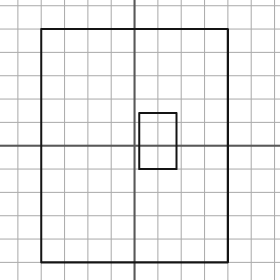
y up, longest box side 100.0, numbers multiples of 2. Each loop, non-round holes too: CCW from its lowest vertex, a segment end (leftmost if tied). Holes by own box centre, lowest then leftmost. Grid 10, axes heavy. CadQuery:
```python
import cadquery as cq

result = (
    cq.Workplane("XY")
    .moveTo(-40.0, -50.0)
    .lineTo(40.0, -50.0)
    .lineTo(40.0, 50.0)
    .lineTo(-40.0, 50.0)
    .close()
    .moveTo(2.0, -10.0)
    .lineTo(18.0, -10.0)
    .lineTo(18.0, 14.0)
    .lineTo(2.0, 14.0)
    .close()
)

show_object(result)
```